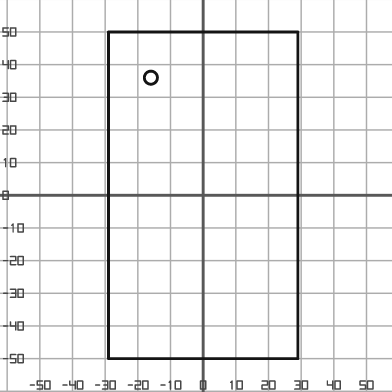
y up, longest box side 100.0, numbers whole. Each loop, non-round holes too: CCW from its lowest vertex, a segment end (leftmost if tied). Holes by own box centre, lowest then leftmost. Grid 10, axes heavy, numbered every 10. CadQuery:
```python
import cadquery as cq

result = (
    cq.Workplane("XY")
    .moveTo(-29.0, -50.0)
    .lineTo(29.0, -50.0)
    .lineTo(29.0, 50.0)
    .lineTo(-29.0, 50.0)
    .close()
    .moveTo(-16.0, 36.0)
    .circle(2.0)
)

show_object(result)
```